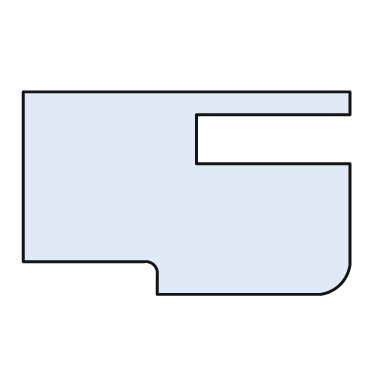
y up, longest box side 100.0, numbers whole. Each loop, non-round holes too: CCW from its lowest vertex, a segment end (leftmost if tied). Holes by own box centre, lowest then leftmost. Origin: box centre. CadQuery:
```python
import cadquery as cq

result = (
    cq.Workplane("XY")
    .moveTo(-9.0, -31.0)
    .lineTo(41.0, -31.0)
    .threePointArc((47.0, -28.0), (50.0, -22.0))
    .lineTo(50.0, 9.0)
    .lineTo(3.0, 9.0)
    .lineTo(3.0, 24.0)
    .lineTo(50.0, 24.0)
    .lineTo(50.0, 31.0)
    .lineTo(-50.0, 31.0)
    .lineTo(-50.0, -21.0)
    .lineTo(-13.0, -21.0)
    .threePointArc((-10.0, -22.0), (-9.0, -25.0))
    .close()
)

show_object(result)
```